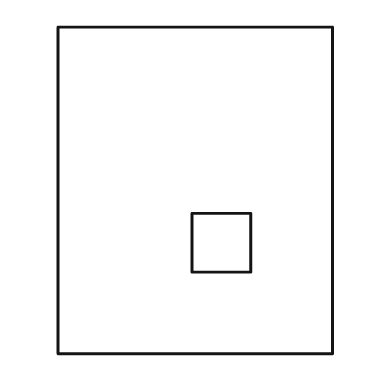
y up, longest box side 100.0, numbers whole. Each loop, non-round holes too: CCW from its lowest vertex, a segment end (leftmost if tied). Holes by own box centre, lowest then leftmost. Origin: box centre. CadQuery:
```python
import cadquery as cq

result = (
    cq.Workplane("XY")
    .moveTo(-42.0, -50.0)
    .lineTo(42.0, -50.0)
    .lineTo(42.0, 50.0)
    .lineTo(-42.0, 50.0)
    .close()
    .moveTo(-1.0, -25.0)
    .lineTo(17.0, -25.0)
    .lineTo(17.0, -7.0)
    .lineTo(-1.0, -7.0)
    .close()
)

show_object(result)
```